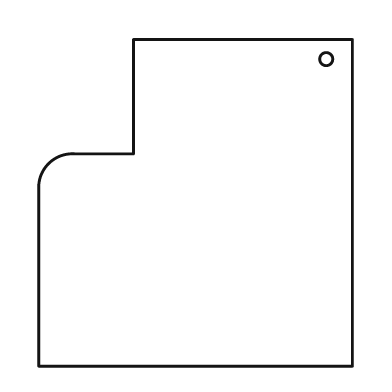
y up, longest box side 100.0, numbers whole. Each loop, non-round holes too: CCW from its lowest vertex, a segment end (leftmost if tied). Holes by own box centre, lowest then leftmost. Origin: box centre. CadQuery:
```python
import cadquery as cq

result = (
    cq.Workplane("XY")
    .moveTo(-48.0, -50.0)
    .lineTo(48.0, -50.0)
    .lineTo(48.0, 50.0)
    .lineTo(-19.0, 50.0)
    .lineTo(-19.0, 15.0)
    .lineTo(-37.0, 15.0)
    .threePointArc((-45.0, 12.0), (-48.0, 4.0))
    .close()
    .moveTo(40.0, 44.0)
    .circle(2.0)
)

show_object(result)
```